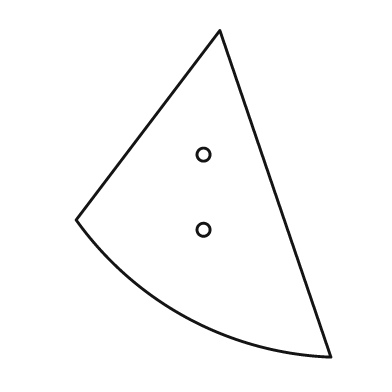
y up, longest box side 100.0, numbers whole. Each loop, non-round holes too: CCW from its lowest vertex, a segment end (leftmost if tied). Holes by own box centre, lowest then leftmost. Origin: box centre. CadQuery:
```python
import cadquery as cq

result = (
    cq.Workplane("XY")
    .moveTo(39.0, -50.0)
    .lineTo(5.0, 50.0)
    .lineTo(-39.0, -8.0)
    .threePointArc((-5.0, -38.0), (39.0, -50.0))
    .close()
    .moveTo(0.0, -11.0)
    .circle(2.0)
    .moveTo(0.0, 12.0)
    .circle(2.0)
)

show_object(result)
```